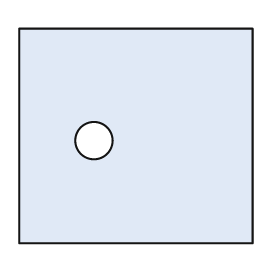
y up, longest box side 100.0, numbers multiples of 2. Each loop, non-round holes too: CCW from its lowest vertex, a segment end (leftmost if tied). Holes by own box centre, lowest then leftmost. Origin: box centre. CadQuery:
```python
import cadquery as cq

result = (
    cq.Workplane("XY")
    .moveTo(-50.0, -46.0)
    .lineTo(50.0, -46.0)
    .lineTo(50.0, 46.0)
    .lineTo(-50.0, 46.0)
    .close()
    .moveTo(-18.0, -2.0)
    .circle(8.0)
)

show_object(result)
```